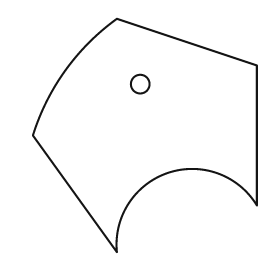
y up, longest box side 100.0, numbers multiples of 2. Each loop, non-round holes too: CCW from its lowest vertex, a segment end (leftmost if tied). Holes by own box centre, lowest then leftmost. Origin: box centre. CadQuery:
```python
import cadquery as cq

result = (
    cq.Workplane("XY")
    .moveTo(-12.0, -50.0)
    .threePointArc((10.0, -16.0), (48.0, -30.0))
    .lineTo(48.0, 30.0)
    .lineTo(-12.0, 50.0)
    .threePointArc((-34.0, 28.0), (-48.0, 0.0))
    .close()
    .moveTo(-2.0, 22.0)
    .circle(4.0)
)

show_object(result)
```